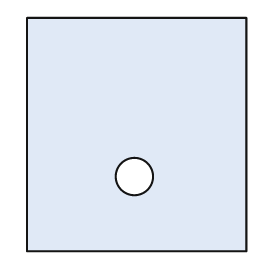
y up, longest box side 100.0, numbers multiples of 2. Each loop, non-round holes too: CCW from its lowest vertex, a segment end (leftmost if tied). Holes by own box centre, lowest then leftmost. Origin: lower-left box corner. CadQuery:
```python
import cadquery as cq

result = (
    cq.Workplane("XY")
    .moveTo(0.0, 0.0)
    .lineTo(94.0, 0.0)
    .lineTo(94.0, 100.0)
    .lineTo(0.0, 100.0)
    .close()
    .moveTo(46.0, 32.0)
    .circle(8.0)
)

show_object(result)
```